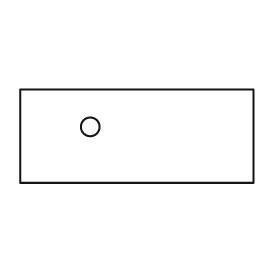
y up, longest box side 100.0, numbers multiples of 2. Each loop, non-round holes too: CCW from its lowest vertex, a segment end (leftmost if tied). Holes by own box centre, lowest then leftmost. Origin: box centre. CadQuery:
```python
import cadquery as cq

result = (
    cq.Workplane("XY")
    .moveTo(-50.0, -20.0)
    .lineTo(50.0, -20.0)
    .lineTo(50.0, 20.0)
    .lineTo(-50.0, 20.0)
    .close()
    .moveTo(-20.0, 4.0)
    .circle(4.0)
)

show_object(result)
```